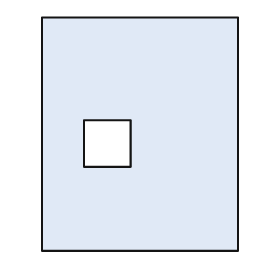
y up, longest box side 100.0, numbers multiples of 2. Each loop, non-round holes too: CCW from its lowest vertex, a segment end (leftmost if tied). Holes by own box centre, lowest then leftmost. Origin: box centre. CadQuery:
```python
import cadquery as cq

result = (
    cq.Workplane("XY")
    .moveTo(-42.0, -50.0)
    .lineTo(42.0, -50.0)
    .lineTo(42.0, 50.0)
    .lineTo(-42.0, 50.0)
    .close()
    .moveTo(-24.0, -14.0)
    .lineTo(-4.0, -14.0)
    .lineTo(-4.0, 6.0)
    .lineTo(-24.0, 6.0)
    .close()
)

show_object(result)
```